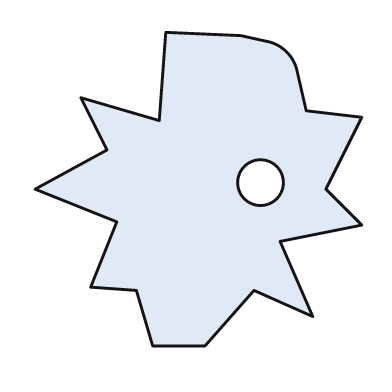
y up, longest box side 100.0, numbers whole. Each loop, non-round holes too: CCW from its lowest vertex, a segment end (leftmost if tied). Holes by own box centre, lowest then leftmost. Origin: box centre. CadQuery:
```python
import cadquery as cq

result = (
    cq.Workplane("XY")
    .moveTo(-14.0, -48.0)
    .lineTo(2.0, -48.0)
    .lineTo(17.0, -31.0)
    .lineTo(35.0, -39.0)
    .lineTo(25.0, -16.0)
    .lineTo(50.0, -11.0)
    .lineTo(39.0, 0.0)
    .lineTo(50.0, 22.0)
    .lineTo(33.0, 24.0)
    .lineTo(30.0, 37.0)
    .threePointArc((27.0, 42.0), (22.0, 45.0))
    .lineTo(13.0, 47.0)
    .lineTo(-10.0, 48.0)
    .lineTo(-12.0, 21.0)
    .lineTo(-36.0, 28.0)
    .lineTo(-28.0, 12.0)
    .lineTo(-50.0, 0.0)
    .lineTo(-25.0, -10.0)
    .lineTo(-33.0, -30.0)
    .lineTo(-19.0, -31.0)
    .close()
    .moveTo(19.0, 2.0)
    .circle(7.0)
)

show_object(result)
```